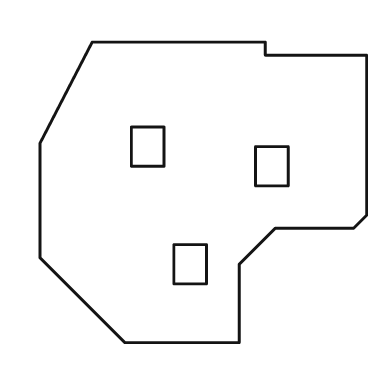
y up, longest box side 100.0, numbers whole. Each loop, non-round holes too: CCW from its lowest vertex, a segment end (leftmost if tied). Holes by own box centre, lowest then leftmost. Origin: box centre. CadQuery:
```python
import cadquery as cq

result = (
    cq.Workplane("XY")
    .moveTo(-24.0, -46.0)
    .lineTo(11.0, -46.0)
    .lineTo(11.0, -22.0)
    .lineTo(22.0, -11.0)
    .lineTo(46.0, -11.0)
    .lineTo(50.0, -7.0)
    .lineTo(50.0, 42.0)
    .lineTo(19.0, 42.0)
    .lineTo(19.0, 46.0)
    .lineTo(-34.0, 46.0)
    .lineTo(-50.0, 15.0)
    .lineTo(-50.0, -20.0)
    .close()
    .moveTo(-9.0, -28.0)
    .lineTo(1.0, -28.0)
    .lineTo(1.0, -16.0)
    .lineTo(-9.0, -16.0)
    .close()
    .moveTo(16.0, 2.0)
    .lineTo(26.0, 2.0)
    .lineTo(26.0, 14.0)
    .lineTo(16.0, 14.0)
    .close()
    .moveTo(-22.0, 8.0)
    .lineTo(-12.0, 8.0)
    .lineTo(-12.0, 20.0)
    .lineTo(-22.0, 20.0)
    .close()
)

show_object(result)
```